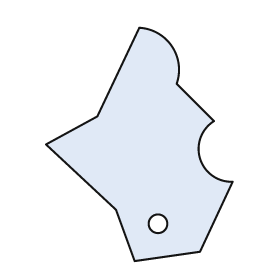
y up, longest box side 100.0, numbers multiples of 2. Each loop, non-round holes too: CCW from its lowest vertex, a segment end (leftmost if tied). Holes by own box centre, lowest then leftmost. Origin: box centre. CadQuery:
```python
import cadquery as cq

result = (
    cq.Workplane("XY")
    .moveTo(-2.0, -50.0)
    .lineTo(26.0, -46.0)
    .lineTo(40.0, -16.0)
    .threePointArc((26.0, -6.0), (32.0, 10.0))
    .lineTo(16.0, 26.0)
    .threePointArc((14.0, 42.0), (0.0, 50.0))
    .lineTo(-18.0, 12.0)
    .lineTo(-40.0, 0.0)
    .lineTo(-10.0, -28.0)
    .close()
    .moveTo(8.0, -34.0)
    .circle(4.0)
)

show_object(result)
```